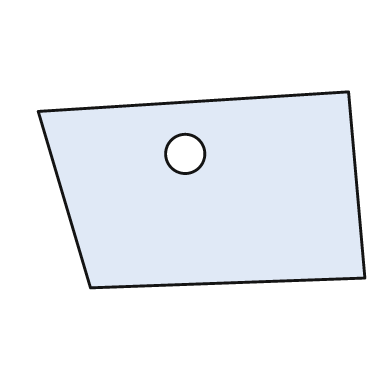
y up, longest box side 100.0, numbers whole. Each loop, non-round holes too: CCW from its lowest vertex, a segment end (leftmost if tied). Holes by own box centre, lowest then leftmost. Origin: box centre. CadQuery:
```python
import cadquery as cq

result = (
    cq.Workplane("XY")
    .moveTo(-34.0, -30.0)
    .lineTo(50.0, -27.0)
    .lineTo(45.0, 30.0)
    .lineTo(-50.0, 24.0)
    .close()
    .moveTo(-5.0, 11.0)
    .circle(6.0)
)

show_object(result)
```